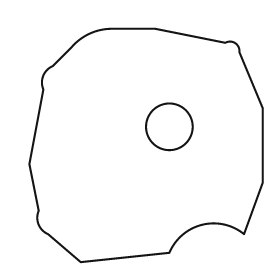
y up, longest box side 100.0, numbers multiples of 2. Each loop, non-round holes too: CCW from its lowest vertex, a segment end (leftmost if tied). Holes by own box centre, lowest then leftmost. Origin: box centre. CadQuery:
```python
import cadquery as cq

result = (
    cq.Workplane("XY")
    .moveTo(-28.0, -50.0)
    .lineTo(10.0, -46.0)
    .threePointArc((24.0, -34.0), (42.0, -38.0))
    .lineTo(50.0, -16.0)
    .lineTo(50.0, 16.0)
    .lineTo(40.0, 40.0)
    .threePointArc((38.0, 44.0), (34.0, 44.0))
    .lineTo(4.0, 50.0)
    .lineTo(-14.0, 50.0)
    .threePointArc((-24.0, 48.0), (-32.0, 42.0))
    .lineTo(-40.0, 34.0)
    .threePointArc((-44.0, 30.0), (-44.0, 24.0))
    .lineTo(-50.0, -8.0)
    .lineTo(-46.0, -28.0)
    .threePointArc((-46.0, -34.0), (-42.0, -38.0))
    .close()
    .moveTo(10.0, 8.0)
    .circle(10.0)
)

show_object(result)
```